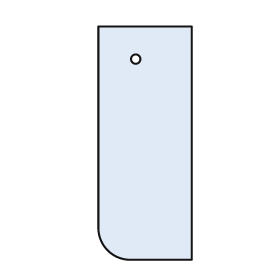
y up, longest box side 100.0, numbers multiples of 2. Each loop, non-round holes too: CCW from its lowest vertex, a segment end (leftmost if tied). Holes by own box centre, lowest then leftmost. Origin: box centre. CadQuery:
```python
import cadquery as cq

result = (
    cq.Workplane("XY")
    .moveTo(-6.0, -50.0)
    .lineTo(20.0, -50.0)
    .lineTo(20.0, 50.0)
    .lineTo(-20.0, 50.0)
    .lineTo(-20.0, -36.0)
    .threePointArc((-16.0, -46.0), (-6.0, -50.0))
    .close()
    .moveTo(-4.0, 36.0)
    .circle(2.0)
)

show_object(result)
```